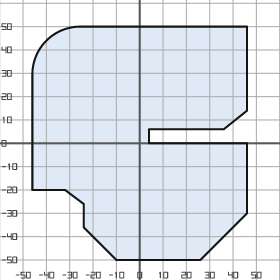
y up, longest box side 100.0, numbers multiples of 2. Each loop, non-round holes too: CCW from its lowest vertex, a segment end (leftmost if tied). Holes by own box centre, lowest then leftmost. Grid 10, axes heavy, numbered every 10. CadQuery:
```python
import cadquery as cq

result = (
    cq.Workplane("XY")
    .moveTo(-10.0, -50.0)
    .lineTo(26.0, -50.0)
    .lineTo(46.0, -30.0)
    .lineTo(46.0, 0.0)
    .lineTo(4.0, 0.0)
    .lineTo(4.0, 6.0)
    .lineTo(36.0, 6.0)
    .lineTo(46.0, 14.0)
    .lineTo(46.0, 50.0)
    .lineTo(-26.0, 50.0)
    .threePointArc((-40.0, 44.0), (-46.0, 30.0))
    .lineTo(-46.0, -20.0)
    .lineTo(-32.0, -20.0)
    .lineTo(-24.0, -26.0)
    .lineTo(-24.0, -36.0)
    .close()
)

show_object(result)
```